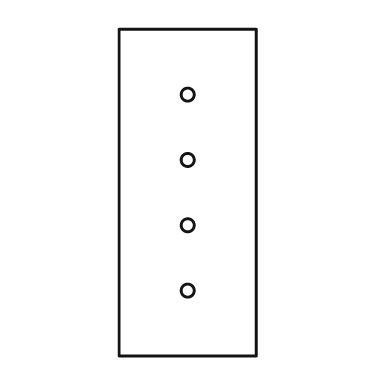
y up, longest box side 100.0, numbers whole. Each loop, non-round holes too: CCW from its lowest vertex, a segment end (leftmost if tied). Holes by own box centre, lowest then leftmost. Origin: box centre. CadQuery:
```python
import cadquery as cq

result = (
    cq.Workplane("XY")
    .moveTo(-21.0, -50.0)
    .lineTo(21.0, -50.0)
    .lineTo(21.0, 50.0)
    .lineTo(-21.0, 50.0)
    .close()
    .moveTo(0.0, -30.0)
    .circle(2.0)
    .moveTo(0.0, -10.0)
    .circle(2.0)
    .moveTo(0.0, 10.0)
    .circle(2.0)
    .moveTo(0.0, 30.0)
    .circle(2.0)
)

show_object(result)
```